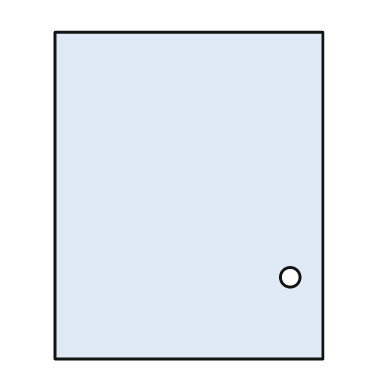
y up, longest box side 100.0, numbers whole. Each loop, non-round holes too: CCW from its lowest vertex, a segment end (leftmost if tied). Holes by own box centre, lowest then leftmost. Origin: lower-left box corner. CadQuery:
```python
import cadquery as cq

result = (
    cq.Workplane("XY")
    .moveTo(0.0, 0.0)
    .lineTo(82.0, 0.0)
    .lineTo(82.0, 100.0)
    .lineTo(0.0, 100.0)
    .close()
    .moveTo(72.0, 25.0)
    .circle(3.0)
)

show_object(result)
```